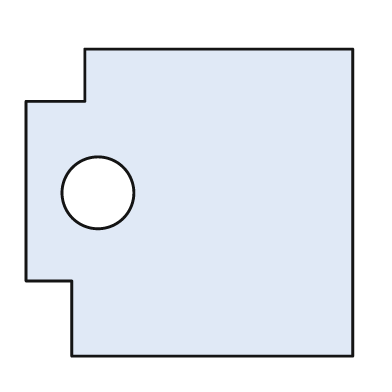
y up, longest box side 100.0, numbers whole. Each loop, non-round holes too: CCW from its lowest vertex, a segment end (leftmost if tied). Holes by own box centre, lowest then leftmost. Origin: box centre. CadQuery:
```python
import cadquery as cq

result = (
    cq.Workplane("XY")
    .moveTo(-36.0, -47.0)
    .lineTo(50.0, -47.0)
    .lineTo(50.0, 47.0)
    .lineTo(-32.0, 47.0)
    .lineTo(-32.0, 31.0)
    .lineTo(-50.0, 31.0)
    .lineTo(-50.0, -24.0)
    .lineTo(-36.0, -24.0)
    .close()
    .moveTo(-28.0, 3.0)
    .circle(11.0)
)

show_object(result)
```